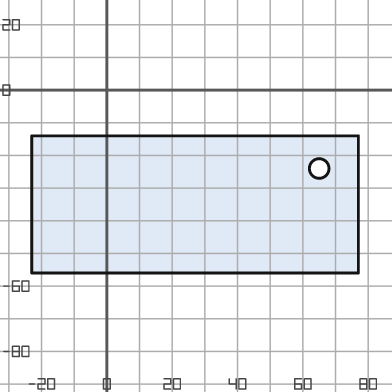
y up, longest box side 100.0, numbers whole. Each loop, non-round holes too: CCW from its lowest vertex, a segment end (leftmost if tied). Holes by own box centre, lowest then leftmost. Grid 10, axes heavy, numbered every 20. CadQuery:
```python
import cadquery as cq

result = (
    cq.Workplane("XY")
    .moveTo(-23.0, -56.0)
    .lineTo(77.0, -56.0)
    .lineTo(77.0, -14.0)
    .lineTo(-23.0, -14.0)
    .close()
    .moveTo(65.0, -24.0)
    .circle(3.0)
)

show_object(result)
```